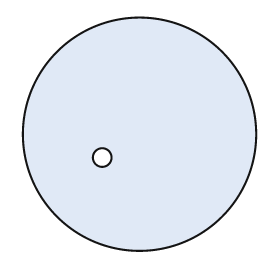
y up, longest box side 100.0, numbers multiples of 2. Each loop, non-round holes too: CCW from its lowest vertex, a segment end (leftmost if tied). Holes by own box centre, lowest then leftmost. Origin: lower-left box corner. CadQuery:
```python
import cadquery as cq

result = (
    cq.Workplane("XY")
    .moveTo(50.0, 50.0)
    .circle(50.0)
    .moveTo(34.0, 40.0)
    .circle(4.0)
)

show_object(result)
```